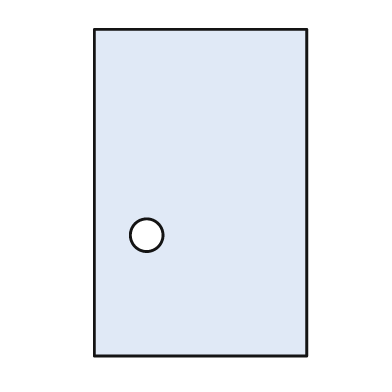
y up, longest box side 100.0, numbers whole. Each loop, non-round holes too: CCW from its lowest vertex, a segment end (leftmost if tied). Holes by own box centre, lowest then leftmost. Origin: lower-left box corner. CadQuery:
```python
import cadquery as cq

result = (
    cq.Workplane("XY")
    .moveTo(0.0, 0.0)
    .lineTo(65.0, 0.0)
    .lineTo(65.0, 100.0)
    .lineTo(0.0, 100.0)
    .close()
    .moveTo(16.0, 37.0)
    .circle(5.0)
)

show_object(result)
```